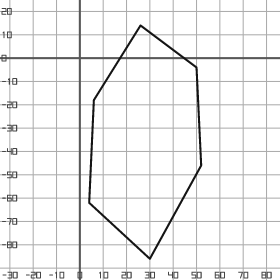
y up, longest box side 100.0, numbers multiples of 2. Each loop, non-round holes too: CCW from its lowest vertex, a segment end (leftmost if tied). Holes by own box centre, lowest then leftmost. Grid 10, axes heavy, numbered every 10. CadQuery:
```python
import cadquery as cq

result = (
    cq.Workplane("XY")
    .moveTo(30.0, -86.0)
    .lineTo(52.0, -46.0)
    .lineTo(50.0, -4.0)
    .lineTo(26.0, 14.0)
    .lineTo(6.0, -18.0)
    .lineTo(4.0, -62.0)
    .close()
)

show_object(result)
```